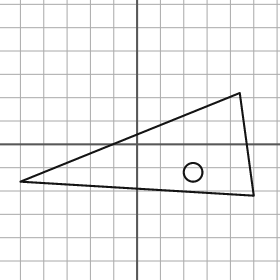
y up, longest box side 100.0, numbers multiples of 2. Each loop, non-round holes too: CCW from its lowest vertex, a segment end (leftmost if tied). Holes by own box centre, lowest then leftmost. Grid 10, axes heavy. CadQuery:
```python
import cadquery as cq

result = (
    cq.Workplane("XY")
    .moveTo(50.0, -22.0)
    .lineTo(44.0, 22.0)
    .lineTo(-50.0, -16.0)
    .close()
    .moveTo(24.0, -12.0)
    .circle(4.0)
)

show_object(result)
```